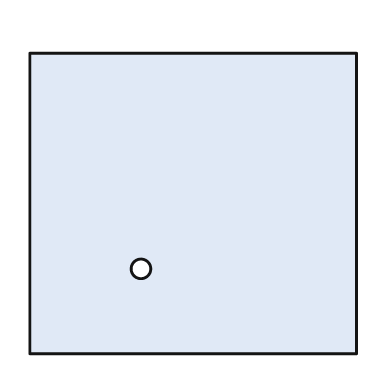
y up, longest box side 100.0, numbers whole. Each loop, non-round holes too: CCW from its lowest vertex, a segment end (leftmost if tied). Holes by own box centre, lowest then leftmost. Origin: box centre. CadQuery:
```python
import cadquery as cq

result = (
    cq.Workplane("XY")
    .moveTo(-50.0, -46.0)
    .lineTo(50.0, -46.0)
    .lineTo(50.0, 46.0)
    .lineTo(-50.0, 46.0)
    .close()
    .moveTo(-16.0, -20.0)
    .circle(3.0)
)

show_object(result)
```